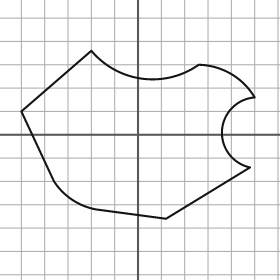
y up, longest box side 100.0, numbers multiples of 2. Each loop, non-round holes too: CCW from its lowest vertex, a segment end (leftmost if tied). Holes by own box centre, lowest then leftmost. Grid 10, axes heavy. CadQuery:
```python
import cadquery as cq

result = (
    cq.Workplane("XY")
    .moveTo(12.0, -36.0)
    .lineTo(48.0, -14.0)
    .threePointArc((36.0, 2.0), (50.0, 16.0))
    .threePointArc((40.0, 26.0), (26.0, 30.0))
    .threePointArc((2.0, 24.0), (-20.0, 36.0))
    .lineTo(-50.0, 10.0)
    .lineTo(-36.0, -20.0)
    .threePointArc((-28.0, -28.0), (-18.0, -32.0))
    .close()
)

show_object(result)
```